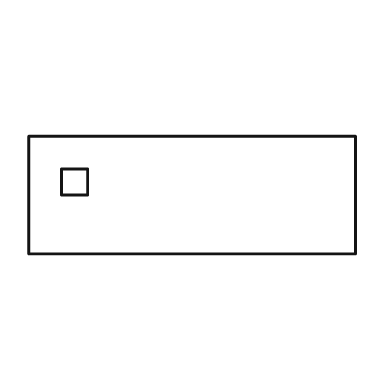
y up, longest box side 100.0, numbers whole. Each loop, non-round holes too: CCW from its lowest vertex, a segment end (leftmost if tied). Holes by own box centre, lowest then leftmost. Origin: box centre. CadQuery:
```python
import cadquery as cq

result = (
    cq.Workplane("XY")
    .moveTo(-50.0, -18.0)
    .lineTo(50.0, -18.0)
    .lineTo(50.0, 18.0)
    .lineTo(-50.0, 18.0)
    .close()
    .moveTo(-40.0, 0.0)
    .lineTo(-32.0, 0.0)
    .lineTo(-32.0, 8.0)
    .lineTo(-40.0, 8.0)
    .close()
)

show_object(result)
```